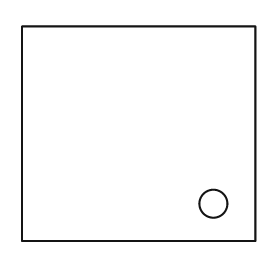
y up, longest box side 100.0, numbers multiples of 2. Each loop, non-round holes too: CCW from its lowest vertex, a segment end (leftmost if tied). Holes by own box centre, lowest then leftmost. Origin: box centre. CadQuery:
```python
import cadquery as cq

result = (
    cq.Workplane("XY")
    .moveTo(-50.0, -46.0)
    .lineTo(50.0, -46.0)
    .lineTo(50.0, 46.0)
    .lineTo(-50.0, 46.0)
    .close()
    .moveTo(32.0, -30.0)
    .circle(6.0)
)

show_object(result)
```